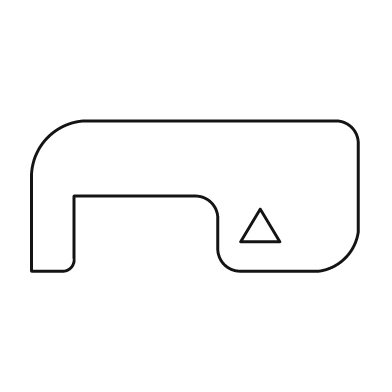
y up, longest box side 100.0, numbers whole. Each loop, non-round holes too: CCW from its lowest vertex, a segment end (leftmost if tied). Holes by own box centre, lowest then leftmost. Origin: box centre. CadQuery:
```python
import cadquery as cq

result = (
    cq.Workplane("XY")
    .moveTo(-50.0, -23.0)
    .lineTo(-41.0, -23.0)
    .threePointArc((-38.0, -22.0), (-37.0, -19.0))
    .lineTo(-37.0, 0.0)
    .lineTo(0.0, 0.0)
    .threePointArc((5.0, -2.0), (7.0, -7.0))
    .lineTo(7.0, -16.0)
    .threePointArc((9.0, -21.0), (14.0, -23.0))
    .lineTo(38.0, -23.0)
    .threePointArc((46.0, -19.0), (50.0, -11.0))
    .lineTo(50.0, 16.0)
    .threePointArc((48.0, 21.0), (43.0, 23.0))
    .lineTo(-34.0, 23.0)
    .threePointArc((-45.0, 18.0), (-50.0, 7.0))
    .close()
    .moveTo(14.0, -14.0)
    .lineTo(26.0, -14.0)
    .lineTo(20.0, -4.0)
    .close()
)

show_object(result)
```